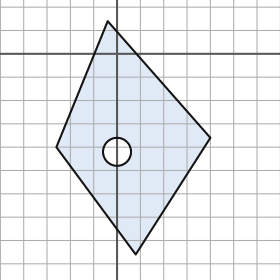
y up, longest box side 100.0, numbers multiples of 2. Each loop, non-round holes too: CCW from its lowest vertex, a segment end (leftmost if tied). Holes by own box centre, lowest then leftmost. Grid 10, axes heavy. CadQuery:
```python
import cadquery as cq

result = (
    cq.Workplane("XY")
    .moveTo(8.0, -86.0)
    .lineTo(40.0, -36.0)
    .lineTo(-4.0, 14.0)
    .lineTo(-26.0, -40.0)
    .close()
    .moveTo(0.0, -42.0)
    .circle(6.0)
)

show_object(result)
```